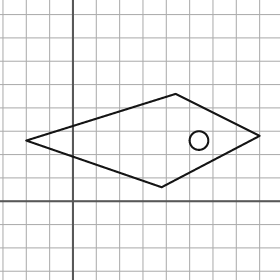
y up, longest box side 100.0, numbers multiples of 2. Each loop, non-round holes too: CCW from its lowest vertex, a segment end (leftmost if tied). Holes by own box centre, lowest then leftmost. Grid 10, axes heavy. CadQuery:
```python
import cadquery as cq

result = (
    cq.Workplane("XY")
    .moveTo(38.0, 6.0)
    .lineTo(80.0, 28.0)
    .lineTo(44.0, 46.0)
    .lineTo(-20.0, 26.0)
    .close()
    .moveTo(54.0, 26.0)
    .circle(4.0)
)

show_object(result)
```